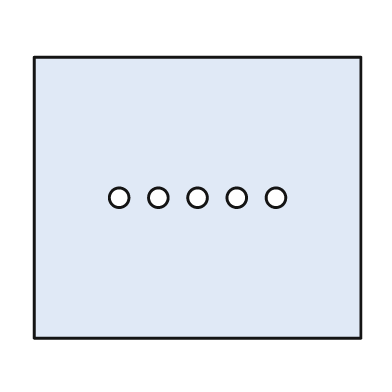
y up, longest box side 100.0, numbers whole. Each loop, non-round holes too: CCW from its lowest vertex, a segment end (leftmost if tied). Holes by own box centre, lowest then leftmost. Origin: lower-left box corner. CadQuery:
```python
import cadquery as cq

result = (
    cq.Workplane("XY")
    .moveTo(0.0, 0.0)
    .lineTo(100.0, 0.0)
    .lineTo(100.0, 86.0)
    .lineTo(0.0, 86.0)
    .close()
    .moveTo(26.0, 43.0)
    .circle(3.0)
    .moveTo(38.0, 43.0)
    .circle(3.0)
    .moveTo(50.0, 43.0)
    .circle(3.0)
    .moveTo(62.0, 43.0)
    .circle(3.0)
    .moveTo(74.0, 43.0)
    .circle(3.0)
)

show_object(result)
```